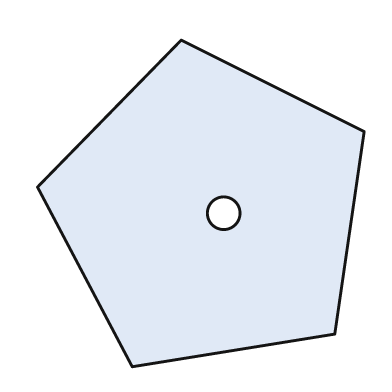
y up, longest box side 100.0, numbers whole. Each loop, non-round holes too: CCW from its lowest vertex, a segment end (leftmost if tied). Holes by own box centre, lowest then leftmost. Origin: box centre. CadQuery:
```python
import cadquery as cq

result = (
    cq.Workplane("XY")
    .moveTo(-21.0, -50.0)
    .lineTo(41.0, -40.0)
    .lineTo(50.0, 22.0)
    .lineTo(-6.0, 50.0)
    .lineTo(-50.0, 5.0)
    .close()
    .moveTo(7.0, -3.0)
    .circle(5.0)
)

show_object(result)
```